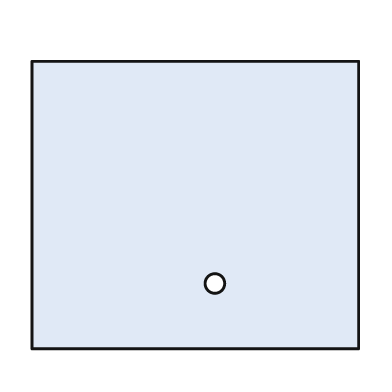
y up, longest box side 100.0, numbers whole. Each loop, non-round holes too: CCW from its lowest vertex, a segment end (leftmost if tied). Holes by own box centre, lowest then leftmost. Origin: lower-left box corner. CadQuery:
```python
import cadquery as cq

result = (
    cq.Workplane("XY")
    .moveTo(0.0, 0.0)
    .lineTo(100.0, 0.0)
    .lineTo(100.0, 88.0)
    .lineTo(0.0, 88.0)
    .close()
    .moveTo(56.0, 20.0)
    .circle(3.0)
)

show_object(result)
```